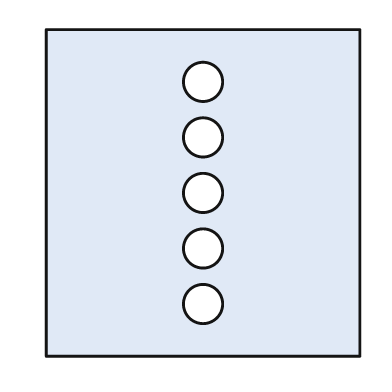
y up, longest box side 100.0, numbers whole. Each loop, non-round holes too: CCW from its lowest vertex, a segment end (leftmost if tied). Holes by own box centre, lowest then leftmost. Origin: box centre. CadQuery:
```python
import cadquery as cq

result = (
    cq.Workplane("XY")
    .moveTo(-48.0, -50.0)
    .lineTo(48.0, -50.0)
    .lineTo(48.0, 50.0)
    .lineTo(-48.0, 50.0)
    .close()
    .moveTo(0.0, -34.0)
    .circle(6.0)
    .moveTo(0.0, -17.0)
    .circle(6.0)
    .moveTo(0.0, 0.0)
    .circle(6.0)
    .moveTo(0.0, 17.0)
    .circle(6.0)
    .moveTo(0.0, 34.0)
    .circle(6.0)
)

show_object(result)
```